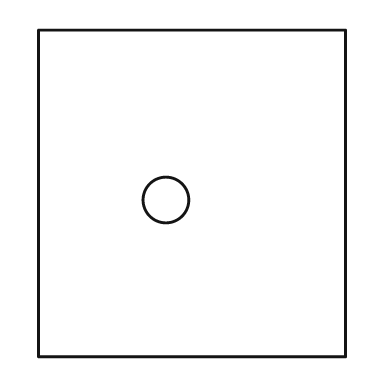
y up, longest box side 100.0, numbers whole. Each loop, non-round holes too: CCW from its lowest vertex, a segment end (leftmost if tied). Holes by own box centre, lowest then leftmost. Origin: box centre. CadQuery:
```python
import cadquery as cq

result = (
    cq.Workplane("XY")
    .moveTo(-47.0, -50.0)
    .lineTo(47.0, -50.0)
    .lineTo(47.0, 50.0)
    .lineTo(-47.0, 50.0)
    .close()
    .moveTo(-8.0, -2.0)
    .circle(7.0)
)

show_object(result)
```